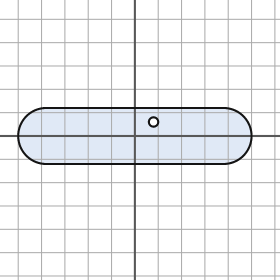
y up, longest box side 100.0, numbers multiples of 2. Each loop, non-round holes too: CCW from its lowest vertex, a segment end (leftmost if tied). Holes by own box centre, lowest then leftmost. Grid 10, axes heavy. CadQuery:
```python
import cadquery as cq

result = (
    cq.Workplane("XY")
    .moveTo(-38.0, -12.0)
    .lineTo(38.0, -12.0)
    .threePointArc((50.0, 0.0), (38.0, 12.0))
    .lineTo(-38.0, 12.0)
    .threePointArc((-50.0, 0.0), (-38.0, -12.0))
    .close()
    .moveTo(8.0, 6.0)
    .circle(2.0)
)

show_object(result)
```